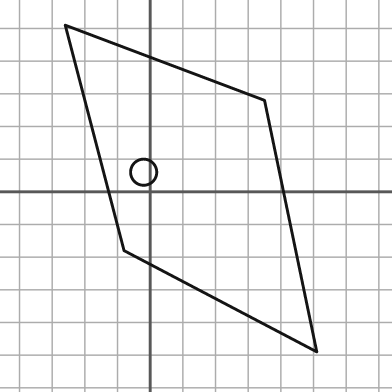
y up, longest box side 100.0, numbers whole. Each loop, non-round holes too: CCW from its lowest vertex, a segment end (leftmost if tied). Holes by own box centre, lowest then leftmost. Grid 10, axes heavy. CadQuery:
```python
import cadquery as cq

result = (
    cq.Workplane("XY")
    .moveTo(51.0, -49.0)
    .lineTo(35.0, 28.0)
    .lineTo(-26.0, 51.0)
    .lineTo(-8.0, -18.0)
    .close()
    .moveTo(-2.0, 6.0)
    .circle(4.0)
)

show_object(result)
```